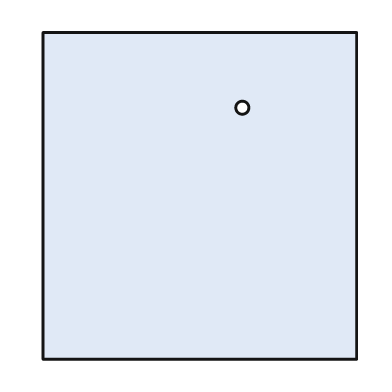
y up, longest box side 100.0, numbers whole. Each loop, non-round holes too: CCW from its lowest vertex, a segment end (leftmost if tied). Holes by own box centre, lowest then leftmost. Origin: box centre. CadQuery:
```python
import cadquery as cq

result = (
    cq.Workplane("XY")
    .moveTo(-48.0, -50.0)
    .lineTo(48.0, -50.0)
    .lineTo(48.0, 50.0)
    .lineTo(-48.0, 50.0)
    .close()
    .moveTo(13.0, 27.0)
    .circle(2.0)
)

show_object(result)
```